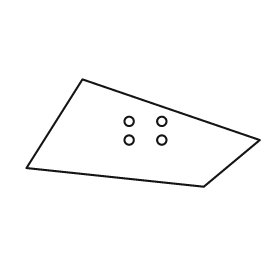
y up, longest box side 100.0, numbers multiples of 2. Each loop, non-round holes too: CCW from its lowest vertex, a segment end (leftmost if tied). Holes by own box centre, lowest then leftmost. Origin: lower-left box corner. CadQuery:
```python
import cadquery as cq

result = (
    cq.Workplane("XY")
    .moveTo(76.0, 0.0)
    .lineTo(100.0, 20.0)
    .lineTo(24.0, 46.0)
    .lineTo(0.0, 8.0)
    .close()
    .moveTo(44.0, 20.0)
    .circle(2.0)
    .moveTo(58.0, 20.0)
    .circle(2.0)
    .moveTo(44.0, 28.0)
    .circle(2.0)
    .moveTo(58.0, 28.0)
    .circle(2.0)
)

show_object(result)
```